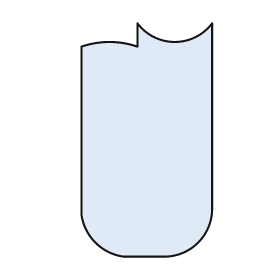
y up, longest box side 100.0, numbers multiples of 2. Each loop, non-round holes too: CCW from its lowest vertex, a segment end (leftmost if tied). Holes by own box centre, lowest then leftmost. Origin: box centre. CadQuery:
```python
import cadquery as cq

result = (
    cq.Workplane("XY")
    .moveTo(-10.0, -50.0)
    .lineTo(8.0, -50.0)
    .threePointArc((22.0, -44.0), (28.0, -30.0))
    .lineTo(28.0, 50.0)
    .threePointArc((12.0, 42.0), (-4.0, 50.0))
    .lineTo(-4.0, 40.0)
    .threePointArc((-16.0, 42.0), (-28.0, 40.0))
    .lineTo(-28.0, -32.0)
    .threePointArc((-22.0, -44.0), (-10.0, -50.0))
    .close()
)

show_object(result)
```